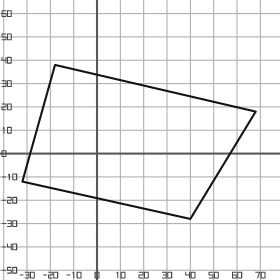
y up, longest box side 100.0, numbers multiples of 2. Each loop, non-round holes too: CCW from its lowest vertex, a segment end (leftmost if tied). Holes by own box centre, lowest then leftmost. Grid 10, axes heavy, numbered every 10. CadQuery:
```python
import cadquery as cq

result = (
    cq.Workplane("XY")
    .moveTo(40.0, -28.0)
    .lineTo(68.0, 18.0)
    .lineTo(-18.0, 38.0)
    .lineTo(-32.0, -12.0)
    .close()
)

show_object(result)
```